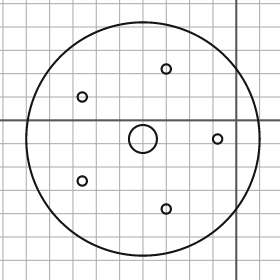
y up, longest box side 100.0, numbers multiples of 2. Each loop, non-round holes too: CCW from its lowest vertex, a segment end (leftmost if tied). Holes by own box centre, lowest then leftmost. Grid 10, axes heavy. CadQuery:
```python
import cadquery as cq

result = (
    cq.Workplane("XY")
    .moveTo(-40.0, -8.0)
    .circle(50.0)
    .moveTo(-30.0, -38.0)
    .circle(2.0)
    .moveTo(-66.0, -26.0)
    .circle(2.0)
    .moveTo(-40.0, -8.0)
    .circle(6.0)
    .moveTo(-8.0, -8.0)
    .circle(2.0)
    .moveTo(-66.0, 10.0)
    .circle(2.0)
    .moveTo(-30.0, 22.0)
    .circle(2.0)
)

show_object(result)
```